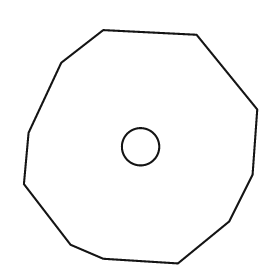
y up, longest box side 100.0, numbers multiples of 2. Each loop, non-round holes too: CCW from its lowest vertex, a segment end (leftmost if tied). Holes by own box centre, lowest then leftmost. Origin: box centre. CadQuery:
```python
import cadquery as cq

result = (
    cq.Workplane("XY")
    .moveTo(16.0, -50.0)
    .lineTo(38.0, -32.0)
    .lineTo(48.0, -12.0)
    .lineTo(50.0, 16.0)
    .lineTo(24.0, 48.0)
    .lineTo(-16.0, 50.0)
    .lineTo(-34.0, 36.0)
    .lineTo(-48.0, 6.0)
    .lineTo(-50.0, -16.0)
    .lineTo(-30.0, -42.0)
    .lineTo(-16.0, -48.0)
    .close()
    .moveTo(0.0, 0.0)
    .circle(8.0)
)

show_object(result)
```